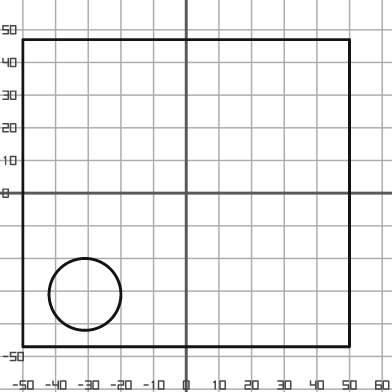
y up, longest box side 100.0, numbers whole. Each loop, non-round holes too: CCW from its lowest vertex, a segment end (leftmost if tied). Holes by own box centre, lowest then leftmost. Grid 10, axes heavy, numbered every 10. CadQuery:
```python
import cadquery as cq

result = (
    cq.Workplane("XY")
    .moveTo(-50.0, -47.0)
    .lineTo(50.0, -47.0)
    .lineTo(50.0, 47.0)
    .lineTo(-50.0, 47.0)
    .close()
    .moveTo(-31.0, -31.0)
    .circle(11.0)
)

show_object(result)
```